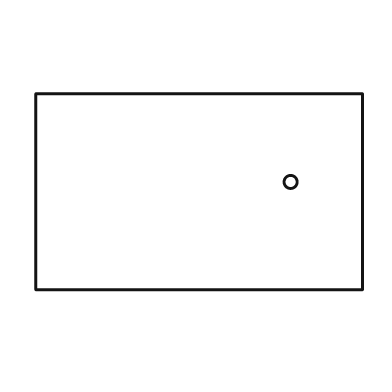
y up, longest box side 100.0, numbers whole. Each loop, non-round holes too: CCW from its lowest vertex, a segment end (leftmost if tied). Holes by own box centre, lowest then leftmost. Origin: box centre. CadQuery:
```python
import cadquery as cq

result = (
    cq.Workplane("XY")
    .moveTo(-50.0, -30.0)
    .lineTo(50.0, -30.0)
    .lineTo(50.0, 30.0)
    .lineTo(-50.0, 30.0)
    .close()
    .moveTo(28.0, 3.0)
    .circle(2.0)
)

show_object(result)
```